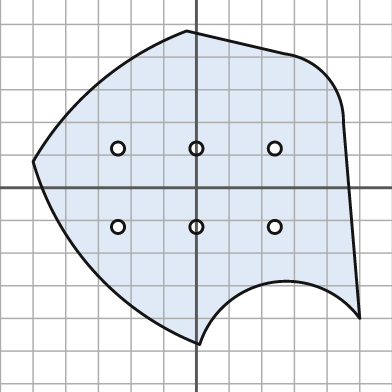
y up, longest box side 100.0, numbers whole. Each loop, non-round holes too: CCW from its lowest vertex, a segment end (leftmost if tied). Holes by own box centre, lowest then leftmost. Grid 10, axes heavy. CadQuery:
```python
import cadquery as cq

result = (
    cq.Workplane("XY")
    .moveTo(1.0, -48.0)
    .threePointArc((23.0, -29.0), (50.0, -40.0))
    .lineTo(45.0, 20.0)
    .threePointArc((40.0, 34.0), (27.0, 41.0))
    .lineTo(-3.0, 48.0)
    .threePointArc((-30.0, 32.0), (-50.0, 8.0))
    .threePointArc((-31.0, -26.0), (1.0, -48.0))
    .close()
    .moveTo(-24.0, -12.0)
    .circle(2.0)
    .moveTo(0.0, -12.0)
    .circle(2.0)
    .moveTo(24.0, -12.0)
    .circle(2.0)
    .moveTo(-24.0, 12.0)
    .circle(2.0)
    .moveTo(0.0, 12.0)
    .circle(2.0)
    .moveTo(24.0, 12.0)
    .circle(2.0)
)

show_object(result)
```